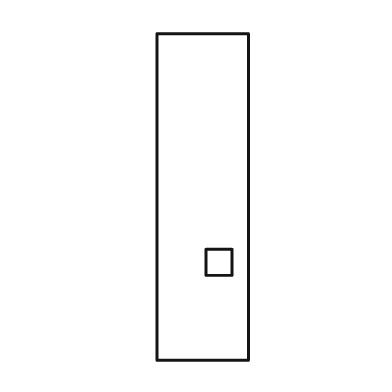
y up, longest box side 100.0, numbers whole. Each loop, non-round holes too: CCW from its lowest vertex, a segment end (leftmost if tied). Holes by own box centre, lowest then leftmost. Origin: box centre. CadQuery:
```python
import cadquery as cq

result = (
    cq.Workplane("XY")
    .moveTo(-14.0, -50.0)
    .lineTo(14.0, -50.0)
    .lineTo(14.0, 50.0)
    .lineTo(-14.0, 50.0)
    .close()
    .moveTo(1.0, -24.0)
    .lineTo(9.0, -24.0)
    .lineTo(9.0, -16.0)
    .lineTo(1.0, -16.0)
    .close()
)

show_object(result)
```